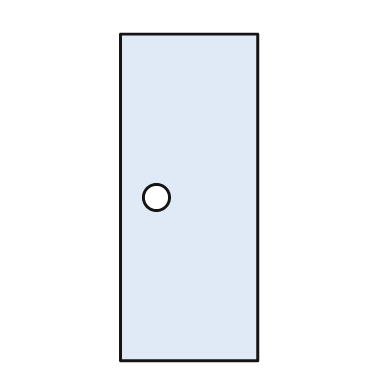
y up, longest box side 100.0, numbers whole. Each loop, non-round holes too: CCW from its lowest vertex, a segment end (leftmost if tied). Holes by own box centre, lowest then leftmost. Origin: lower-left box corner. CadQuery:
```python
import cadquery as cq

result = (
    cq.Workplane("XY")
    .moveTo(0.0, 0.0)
    .lineTo(42.0, 0.0)
    .lineTo(42.0, 100.0)
    .lineTo(0.0, 100.0)
    .close()
    .moveTo(11.0, 50.0)
    .circle(4.0)
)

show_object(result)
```